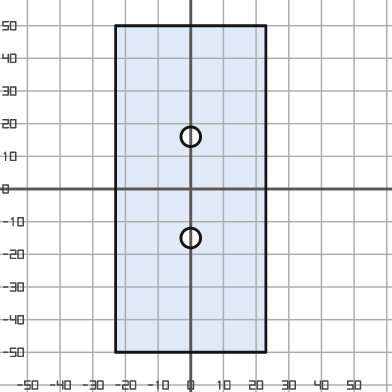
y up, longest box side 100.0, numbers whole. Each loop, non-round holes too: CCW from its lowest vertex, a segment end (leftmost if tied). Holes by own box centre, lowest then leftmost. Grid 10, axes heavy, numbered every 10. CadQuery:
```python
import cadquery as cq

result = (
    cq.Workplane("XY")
    .moveTo(-23.0, -50.0)
    .lineTo(23.0, -50.0)
    .lineTo(23.0, 50.0)
    .lineTo(-23.0, 50.0)
    .close()
    .moveTo(0.0, -15.0)
    .circle(3.0)
    .moveTo(0.0, 16.0)
    .circle(3.0)
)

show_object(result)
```